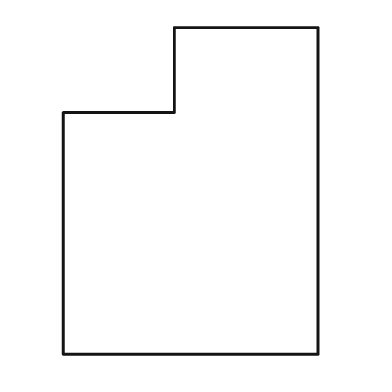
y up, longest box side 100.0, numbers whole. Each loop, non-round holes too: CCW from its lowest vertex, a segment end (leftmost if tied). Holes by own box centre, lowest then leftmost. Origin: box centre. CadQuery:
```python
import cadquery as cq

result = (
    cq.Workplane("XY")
    .moveTo(-39.0, -50.0)
    .lineTo(39.0, -50.0)
    .lineTo(39.0, 50.0)
    .lineTo(-5.0, 50.0)
    .lineTo(-5.0, 24.0)
    .lineTo(-39.0, 24.0)
    .close()
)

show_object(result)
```